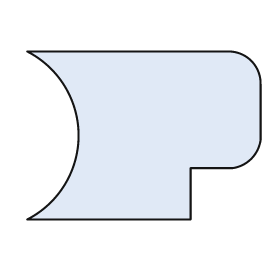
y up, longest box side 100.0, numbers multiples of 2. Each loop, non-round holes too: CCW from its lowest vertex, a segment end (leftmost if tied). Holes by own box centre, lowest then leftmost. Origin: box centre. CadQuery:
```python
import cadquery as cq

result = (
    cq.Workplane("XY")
    .moveTo(-50.0, -36.0)
    .lineTo(20.0, -36.0)
    .lineTo(20.0, -14.0)
    .lineTo(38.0, -14.0)
    .threePointArc((46.0, -10.0), (50.0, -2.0))
    .lineTo(50.0, 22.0)
    .threePointArc((46.0, 32.0), (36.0, 36.0))
    .lineTo(-50.0, 36.0)
    .threePointArc((-28.0, 0.0), (-50.0, -36.0))
    .close()
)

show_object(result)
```